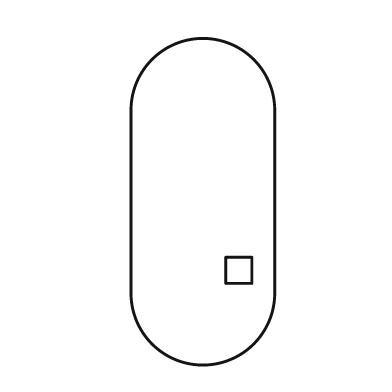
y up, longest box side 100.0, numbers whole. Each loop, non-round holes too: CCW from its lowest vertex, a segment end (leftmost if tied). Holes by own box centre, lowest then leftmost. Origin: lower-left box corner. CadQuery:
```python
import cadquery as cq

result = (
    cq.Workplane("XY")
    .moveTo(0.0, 22.0)
    .threePointArc((22.0, 0.0), (44.0, 22.0))
    .lineTo(44.0, 78.0)
    .threePointArc((22.0, 100.0), (0.0, 78.0))
    .close()
    .moveTo(29.0, 25.0)
    .lineTo(37.0, 25.0)
    .lineTo(37.0, 33.0)
    .lineTo(29.0, 33.0)
    .close()
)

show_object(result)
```